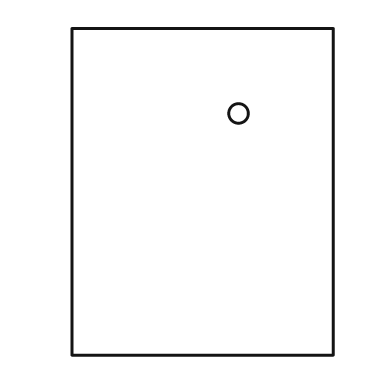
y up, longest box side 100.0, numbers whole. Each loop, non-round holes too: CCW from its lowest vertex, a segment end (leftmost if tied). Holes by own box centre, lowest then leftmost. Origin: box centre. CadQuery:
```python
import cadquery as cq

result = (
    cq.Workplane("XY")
    .moveTo(-40.0, -50.0)
    .lineTo(40.0, -50.0)
    .lineTo(40.0, 50.0)
    .lineTo(-40.0, 50.0)
    .close()
    .moveTo(11.0, 24.0)
    .circle(3.0)
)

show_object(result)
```